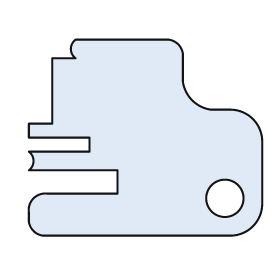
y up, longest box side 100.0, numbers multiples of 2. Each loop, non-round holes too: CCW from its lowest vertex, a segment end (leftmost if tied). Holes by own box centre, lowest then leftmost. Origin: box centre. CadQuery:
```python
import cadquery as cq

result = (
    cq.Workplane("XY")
    .moveTo(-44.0, -42.0)
    .lineTo(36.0, -42.0)
    .threePointArc((46.0, -38.0), (50.0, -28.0))
    .lineTo(50.0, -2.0)
    .threePointArc((46.0, 8.0), (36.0, 12.0))
    .lineTo(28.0, 12.0)
    .threePointArc((20.0, 16.0), (16.0, 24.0))
    .lineTo(16.0, 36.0)
    .threePointArc((14.0, 40.0), (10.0, 42.0))
    .lineTo(-30.0, 42.0)
    .threePointArc((-32.0, 38.0), (-30.0, 34.0))
    .lineTo(-40.0, 34.0)
    .lineTo(-40.0, 6.0)
    .lineTo(-50.0, 6.0)
    .lineTo(-50.0, 0.0)
    .lineTo(-24.0, 0.0)
    .lineTo(-24.0, -6.0)
    .lineTo(-50.0, -6.0)
    .threePointArc((-48.0, -10.0), (-50.0, -14.0))
    .lineTo(-12.0, -14.0)
    .lineTo(-12.0, -24.0)
    .lineTo(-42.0, -24.0)
    .threePointArc((-48.0, -26.0), (-50.0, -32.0))
    .lineTo(-50.0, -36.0)
    .threePointArc((-48.0, -40.0), (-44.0, -42.0))
    .close()
    .moveTo(34.0, -26.0)
    .circle(8.0)
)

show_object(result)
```